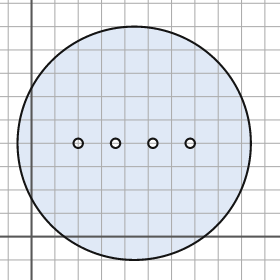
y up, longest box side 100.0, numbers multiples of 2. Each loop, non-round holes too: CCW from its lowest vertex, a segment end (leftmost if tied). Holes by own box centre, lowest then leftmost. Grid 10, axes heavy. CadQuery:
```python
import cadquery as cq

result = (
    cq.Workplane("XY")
    .moveTo(44.0, 40.0)
    .circle(50.0)
    .moveTo(20.0, 40.0)
    .circle(2.0)
    .moveTo(36.0, 40.0)
    .circle(2.0)
    .moveTo(52.0, 40.0)
    .circle(2.0)
    .moveTo(68.0, 40.0)
    .circle(2.0)
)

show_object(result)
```